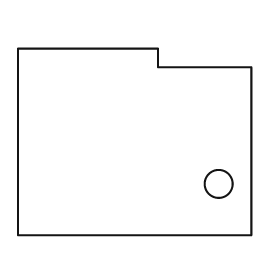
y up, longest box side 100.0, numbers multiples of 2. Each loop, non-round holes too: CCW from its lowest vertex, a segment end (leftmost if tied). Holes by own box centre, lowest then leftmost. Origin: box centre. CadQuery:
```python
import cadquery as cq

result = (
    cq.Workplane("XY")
    .moveTo(-50.0, -40.0)
    .lineTo(50.0, -40.0)
    .lineTo(50.0, 32.0)
    .lineTo(10.0, 32.0)
    .lineTo(10.0, 40.0)
    .lineTo(-50.0, 40.0)
    .close()
    .moveTo(36.0, -18.0)
    .circle(6.0)
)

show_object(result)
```